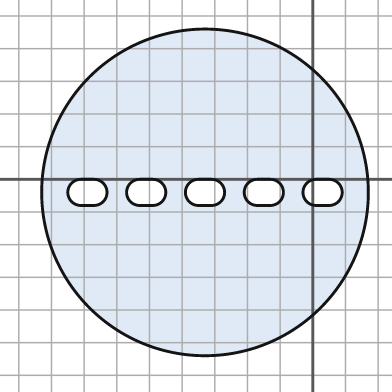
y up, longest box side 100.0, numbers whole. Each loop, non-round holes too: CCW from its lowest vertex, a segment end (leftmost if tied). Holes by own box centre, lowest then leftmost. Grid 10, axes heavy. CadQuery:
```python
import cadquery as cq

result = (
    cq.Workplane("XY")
    .moveTo(-33.0, -4.0)
    .circle(50.0)
    .moveTo(-71.0, -8.0)
    .lineTo(-67.0, -8.0)
    .threePointArc((-63.0, -4.0), (-67.0, 0.0))
    .lineTo(-71.0, 0.0)
    .threePointArc((-75.0, -4.0), (-71.0, -8.0))
    .close()
    .moveTo(-53.0, -8.0)
    .lineTo(-49.0, -8.0)
    .threePointArc((-45.0, -4.0), (-49.0, 0.0))
    .lineTo(-53.0, 0.0)
    .threePointArc((-57.0, -4.0), (-53.0, -8.0))
    .close()
    .moveTo(-35.0, -8.0)
    .lineTo(-31.0, -8.0)
    .threePointArc((-27.0, -4.0), (-31.0, 0.0))
    .lineTo(-35.0, 0.0)
    .threePointArc((-39.0, -4.0), (-35.0, -8.0))
    .close()
    .moveTo(-17.0, -8.0)
    .lineTo(-13.0, -8.0)
    .threePointArc((-9.0, -4.0), (-13.0, 0.0))
    .lineTo(-17.0, 0.0)
    .threePointArc((-21.0, -4.0), (-17.0, -8.0))
    .close()
    .moveTo(1.0, -8.0)
    .lineTo(5.0, -8.0)
    .threePointArc((9.0, -4.0), (5.0, 0.0))
    .lineTo(1.0, 0.0)
    .threePointArc((-3.0, -4.0), (1.0, -8.0))
    .close()
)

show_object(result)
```